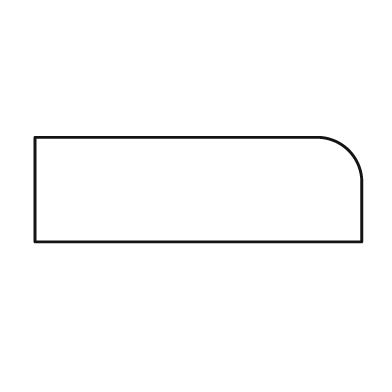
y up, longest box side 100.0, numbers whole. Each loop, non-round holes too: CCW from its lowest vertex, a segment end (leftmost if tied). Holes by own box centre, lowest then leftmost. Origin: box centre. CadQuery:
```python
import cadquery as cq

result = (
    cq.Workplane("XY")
    .moveTo(-50.0, -16.0)
    .lineTo(50.0, -16.0)
    .lineTo(50.0, 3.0)
    .threePointArc((46.0, 12.0), (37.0, 16.0))
    .lineTo(-50.0, 16.0)
    .close()
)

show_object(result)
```